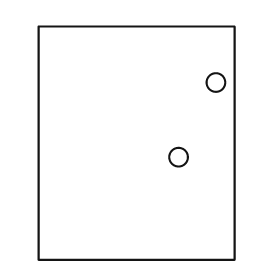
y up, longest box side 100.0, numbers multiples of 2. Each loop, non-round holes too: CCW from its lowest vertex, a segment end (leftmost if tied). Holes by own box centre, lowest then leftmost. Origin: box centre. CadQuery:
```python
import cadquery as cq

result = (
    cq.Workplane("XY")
    .moveTo(-42.0, -50.0)
    .lineTo(42.0, -50.0)
    .lineTo(42.0, 50.0)
    .lineTo(-42.0, 50.0)
    .close()
    .moveTo(18.0, -6.0)
    .circle(4.0)
    .moveTo(34.0, 26.0)
    .circle(4.0)
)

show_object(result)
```